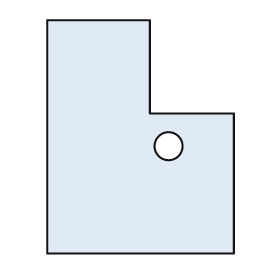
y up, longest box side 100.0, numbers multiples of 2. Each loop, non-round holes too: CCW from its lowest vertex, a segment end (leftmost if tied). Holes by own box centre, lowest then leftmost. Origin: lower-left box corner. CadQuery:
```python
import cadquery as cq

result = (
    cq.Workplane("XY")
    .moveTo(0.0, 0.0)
    .lineTo(80.0, 0.0)
    .lineTo(80.0, 60.0)
    .lineTo(44.0, 60.0)
    .lineTo(44.0, 100.0)
    .lineTo(0.0, 100.0)
    .close()
    .moveTo(52.0, 46.0)
    .circle(6.0)
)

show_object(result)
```